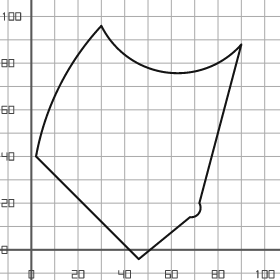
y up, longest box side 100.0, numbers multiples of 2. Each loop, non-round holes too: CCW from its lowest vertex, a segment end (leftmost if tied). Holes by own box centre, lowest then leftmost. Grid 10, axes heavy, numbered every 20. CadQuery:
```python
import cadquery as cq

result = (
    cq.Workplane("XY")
    .moveTo(46.0, -4.0)
    .lineTo(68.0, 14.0)
    .threePointArc((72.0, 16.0), (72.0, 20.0))
    .lineTo(90.0, 88.0)
    .threePointArc((58.0, 76.0), (30.0, 96.0))
    .threePointArc((12.0, 70.0), (2.0, 40.0))
    .close()
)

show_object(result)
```